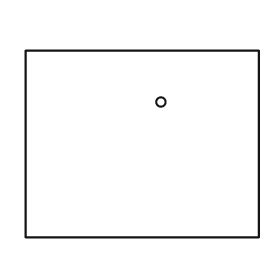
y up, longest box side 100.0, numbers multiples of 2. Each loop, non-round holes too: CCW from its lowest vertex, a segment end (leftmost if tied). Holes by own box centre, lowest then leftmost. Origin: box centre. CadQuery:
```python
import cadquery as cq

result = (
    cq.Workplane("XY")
    .moveTo(-50.0, -40.0)
    .lineTo(50.0, -40.0)
    .lineTo(50.0, 40.0)
    .lineTo(-50.0, 40.0)
    .close()
    .moveTo(8.0, 18.0)
    .circle(2.0)
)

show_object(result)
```